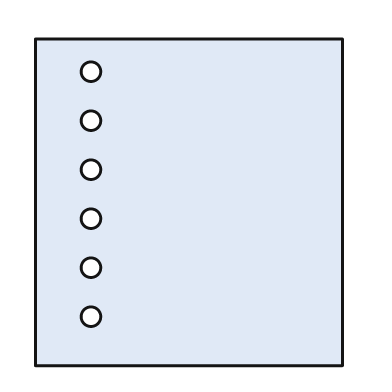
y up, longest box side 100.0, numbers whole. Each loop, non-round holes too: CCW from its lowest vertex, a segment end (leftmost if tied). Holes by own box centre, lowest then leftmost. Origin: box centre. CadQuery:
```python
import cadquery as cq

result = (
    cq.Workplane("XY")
    .moveTo(-47.0, -50.0)
    .lineTo(47.0, -50.0)
    .lineTo(47.0, 50.0)
    .lineTo(-47.0, 50.0)
    .close()
    .moveTo(-30.0, -35.0)
    .circle(3.0)
    .moveTo(-30.0, -20.0)
    .circle(3.0)
    .moveTo(-30.0, -5.0)
    .circle(3.0)
    .moveTo(-30.0, 10.0)
    .circle(3.0)
    .moveTo(-30.0, 25.0)
    .circle(3.0)
    .moveTo(-30.0, 40.0)
    .circle(3.0)
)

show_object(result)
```